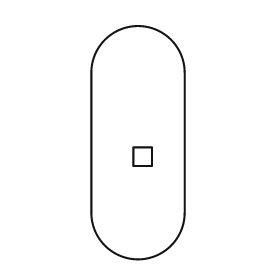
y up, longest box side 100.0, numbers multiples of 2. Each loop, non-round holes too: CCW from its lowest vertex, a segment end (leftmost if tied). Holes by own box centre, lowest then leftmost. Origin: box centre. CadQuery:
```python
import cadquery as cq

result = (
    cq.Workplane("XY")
    .moveTo(-20.0, -30.0)
    .threePointArc((0.0, -50.0), (20.0, -30.0))
    .lineTo(20.0, 30.0)
    .threePointArc((0.0, 50.0), (-20.0, 30.0))
    .close()
    .moveTo(-2.0, -10.0)
    .lineTo(6.0, -10.0)
    .lineTo(6.0, -2.0)
    .lineTo(-2.0, -2.0)
    .close()
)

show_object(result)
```